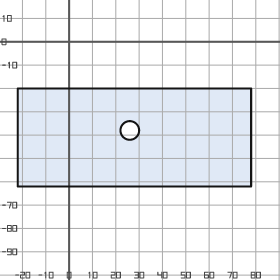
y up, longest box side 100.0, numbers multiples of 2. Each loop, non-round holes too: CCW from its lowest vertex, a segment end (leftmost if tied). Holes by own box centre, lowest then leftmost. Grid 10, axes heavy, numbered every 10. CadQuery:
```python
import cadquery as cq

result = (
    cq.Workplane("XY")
    .moveTo(-22.0, -62.0)
    .lineTo(78.0, -62.0)
    .lineTo(78.0, -20.0)
    .lineTo(-22.0, -20.0)
    .close()
    .moveTo(26.0, -38.0)
    .circle(4.0)
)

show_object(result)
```